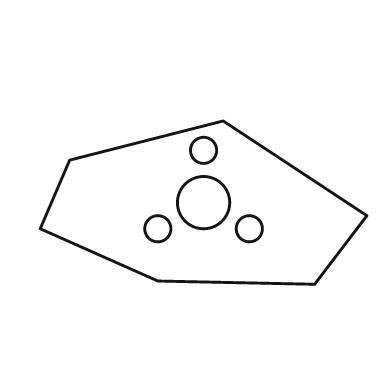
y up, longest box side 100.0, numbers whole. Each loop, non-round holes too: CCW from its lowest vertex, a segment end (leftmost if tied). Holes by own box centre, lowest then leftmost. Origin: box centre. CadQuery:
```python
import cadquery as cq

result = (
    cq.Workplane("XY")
    .moveTo(34.0, -25.0)
    .lineTo(50.0, -4.0)
    .lineTo(6.0, 25.0)
    .lineTo(-41.0, 13.0)
    .lineTo(-50.0, -8.0)
    .lineTo(-14.0, -24.0)
    .close()
    .moveTo(-14.0, -8.0)
    .circle(4.0)
    .moveTo(14.0, -8.0)
    .circle(4.0)
    .moveTo(0.0, 0.0)
    .circle(8.0)
    .moveTo(0.0, 16.0)
    .circle(4.0)
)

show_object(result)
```